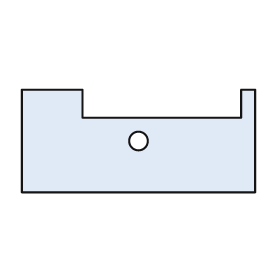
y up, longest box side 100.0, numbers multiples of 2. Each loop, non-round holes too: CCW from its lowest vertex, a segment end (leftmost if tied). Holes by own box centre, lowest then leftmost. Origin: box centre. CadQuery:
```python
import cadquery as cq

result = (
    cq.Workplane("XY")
    .moveTo(-50.0, -22.0)
    .lineTo(50.0, -22.0)
    .lineTo(50.0, 22.0)
    .lineTo(44.0, 22.0)
    .lineTo(44.0, 10.0)
    .lineTo(-24.0, 10.0)
    .lineTo(-24.0, 22.0)
    .lineTo(-50.0, 22.0)
    .close()
    .moveTo(0.0, 0.0)
    .circle(4.0)
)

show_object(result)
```